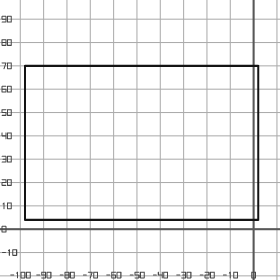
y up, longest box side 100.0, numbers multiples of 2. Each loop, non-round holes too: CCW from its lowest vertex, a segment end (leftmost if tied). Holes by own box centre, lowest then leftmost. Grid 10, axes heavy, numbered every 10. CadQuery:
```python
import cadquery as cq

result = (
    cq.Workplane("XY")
    .moveTo(-98.0, 4.0)
    .lineTo(2.0, 4.0)
    .lineTo(2.0, 70.0)
    .lineTo(-98.0, 70.0)
    .close()
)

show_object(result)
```